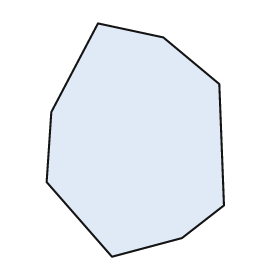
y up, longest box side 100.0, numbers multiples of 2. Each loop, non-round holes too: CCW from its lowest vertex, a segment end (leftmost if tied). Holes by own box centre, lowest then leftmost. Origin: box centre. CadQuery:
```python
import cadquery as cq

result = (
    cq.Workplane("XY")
    .moveTo(-10.0, -50.0)
    .lineTo(20.0, -42.0)
    .lineTo(38.0, -28.0)
    .lineTo(36.0, 24.0)
    .lineTo(12.0, 44.0)
    .lineTo(-16.0, 50.0)
    .lineTo(-36.0, 12.0)
    .lineTo(-38.0, -18.0)
    .close()
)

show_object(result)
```